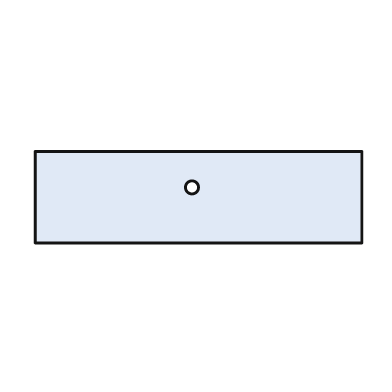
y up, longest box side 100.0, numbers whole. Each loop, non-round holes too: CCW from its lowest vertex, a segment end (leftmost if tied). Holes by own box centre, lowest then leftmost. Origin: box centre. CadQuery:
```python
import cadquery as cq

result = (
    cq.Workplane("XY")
    .moveTo(-50.0, -14.0)
    .lineTo(50.0, -14.0)
    .lineTo(50.0, 14.0)
    .lineTo(-50.0, 14.0)
    .close()
    .moveTo(-2.0, 3.0)
    .circle(2.0)
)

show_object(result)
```